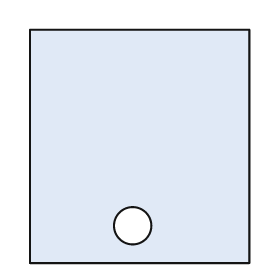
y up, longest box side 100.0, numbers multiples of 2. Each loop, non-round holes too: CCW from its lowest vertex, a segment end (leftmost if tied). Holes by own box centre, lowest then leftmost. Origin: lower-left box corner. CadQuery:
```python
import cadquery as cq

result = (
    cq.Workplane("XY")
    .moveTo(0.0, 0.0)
    .lineTo(94.0, 0.0)
    .lineTo(94.0, 100.0)
    .lineTo(0.0, 100.0)
    .close()
    .moveTo(44.0, 16.0)
    .circle(8.0)
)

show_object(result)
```